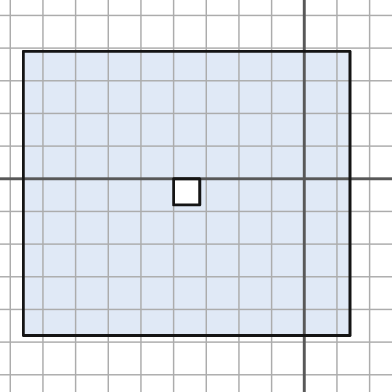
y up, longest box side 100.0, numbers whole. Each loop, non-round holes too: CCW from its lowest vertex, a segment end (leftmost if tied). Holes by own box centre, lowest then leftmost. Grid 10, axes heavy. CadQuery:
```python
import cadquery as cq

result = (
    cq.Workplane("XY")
    .moveTo(-86.0, -48.0)
    .lineTo(14.0, -48.0)
    .lineTo(14.0, 39.0)
    .lineTo(-86.0, 39.0)
    .close()
    .moveTo(-40.0, -8.0)
    .lineTo(-32.0, -8.0)
    .lineTo(-32.0, 0.0)
    .lineTo(-40.0, 0.0)
    .close()
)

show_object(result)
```